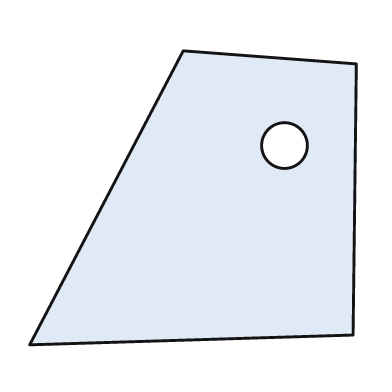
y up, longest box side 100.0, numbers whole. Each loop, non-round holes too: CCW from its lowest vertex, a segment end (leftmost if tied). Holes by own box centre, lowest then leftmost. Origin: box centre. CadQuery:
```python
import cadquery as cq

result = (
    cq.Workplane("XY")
    .moveTo(-50.0, -45.0)
    .lineTo(49.0, -42.0)
    .lineTo(50.0, 41.0)
    .lineTo(-3.0, 45.0)
    .close()
    .moveTo(28.0, 16.0)
    .circle(7.0)
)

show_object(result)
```